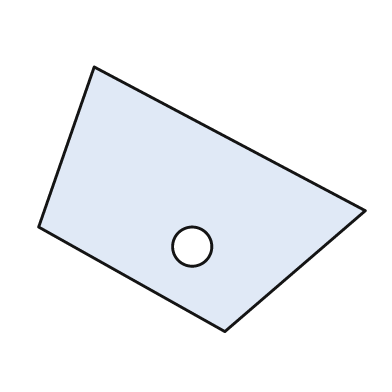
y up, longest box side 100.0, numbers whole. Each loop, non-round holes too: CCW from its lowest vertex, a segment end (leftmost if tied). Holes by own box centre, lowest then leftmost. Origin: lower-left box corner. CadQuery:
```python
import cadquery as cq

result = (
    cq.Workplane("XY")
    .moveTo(57.0, 0.0)
    .lineTo(100.0, 37.0)
    .lineTo(17.0, 81.0)
    .lineTo(0.0, 32.0)
    .close()
    .moveTo(47.0, 26.0)
    .circle(6.0)
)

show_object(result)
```